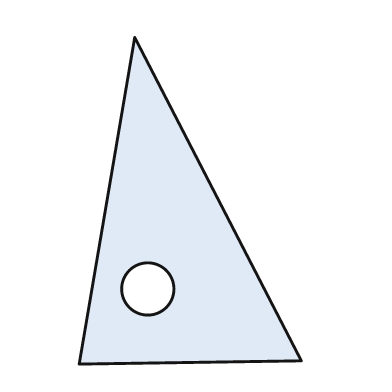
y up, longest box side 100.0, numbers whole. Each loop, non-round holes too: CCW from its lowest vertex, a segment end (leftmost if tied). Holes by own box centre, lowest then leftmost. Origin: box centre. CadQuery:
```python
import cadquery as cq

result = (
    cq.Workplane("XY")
    .moveTo(-34.0, -50.0)
    .lineTo(34.0, -49.0)
    .lineTo(-17.0, 50.0)
    .close()
    .moveTo(-13.0, -27.0)
    .circle(8.0)
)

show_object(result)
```